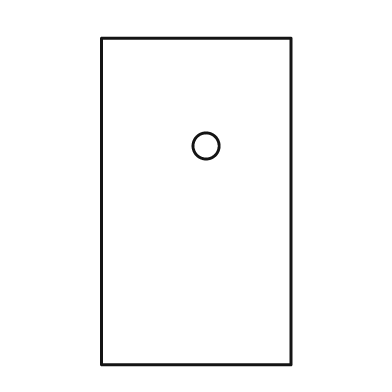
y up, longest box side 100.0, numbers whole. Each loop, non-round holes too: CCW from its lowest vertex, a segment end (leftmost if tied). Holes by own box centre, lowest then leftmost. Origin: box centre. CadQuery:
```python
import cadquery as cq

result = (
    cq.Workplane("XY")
    .moveTo(-29.0, -50.0)
    .lineTo(29.0, -50.0)
    .lineTo(29.0, 50.0)
    .lineTo(-29.0, 50.0)
    .close()
    .moveTo(3.0, 17.0)
    .circle(4.0)
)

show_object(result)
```